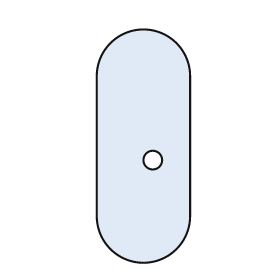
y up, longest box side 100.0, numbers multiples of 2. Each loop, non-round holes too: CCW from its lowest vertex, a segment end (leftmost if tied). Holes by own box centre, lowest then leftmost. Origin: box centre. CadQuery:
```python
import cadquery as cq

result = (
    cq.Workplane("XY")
    .moveTo(-20.0, -30.0)
    .threePointArc((0.0, -50.0), (20.0, -30.0))
    .lineTo(20.0, 30.0)
    .threePointArc((0.0, 50.0), (-20.0, 30.0))
    .close()
    .moveTo(4.0, -6.0)
    .circle(4.0)
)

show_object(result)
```